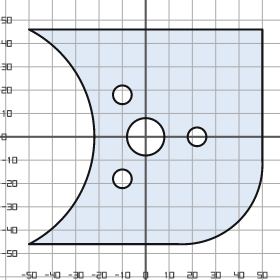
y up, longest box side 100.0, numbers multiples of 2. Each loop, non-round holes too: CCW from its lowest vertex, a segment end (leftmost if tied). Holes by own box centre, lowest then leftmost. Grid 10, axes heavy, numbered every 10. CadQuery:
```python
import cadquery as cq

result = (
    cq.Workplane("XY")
    .moveTo(-50.0, -46.0)
    .lineTo(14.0, -46.0)
    .threePointArc((40.0, -36.0), (50.0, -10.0))
    .lineTo(50.0, 46.0)
    .lineTo(-50.0, 46.0)
    .threePointArc((-22.0, 0.0), (-50.0, -46.0))
    .close()
    .moveTo(-10.0, -18.0)
    .circle(4.0)
    .moveTo(0.0, 0.0)
    .circle(8.0)
    .moveTo(22.0, 0.0)
    .circle(4.0)
    .moveTo(-10.0, 18.0)
    .circle(4.0)
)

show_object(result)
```